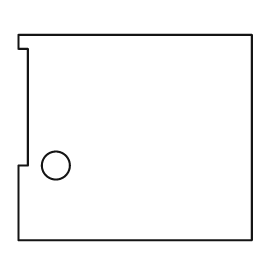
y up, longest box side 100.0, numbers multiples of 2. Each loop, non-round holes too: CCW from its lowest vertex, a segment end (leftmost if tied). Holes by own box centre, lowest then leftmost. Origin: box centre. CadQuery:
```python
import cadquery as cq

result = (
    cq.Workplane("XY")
    .moveTo(-50.0, -44.0)
    .lineTo(50.0, -44.0)
    .lineTo(50.0, 44.0)
    .lineTo(-50.0, 44.0)
    .lineTo(-50.0, 38.0)
    .lineTo(-46.0, 38.0)
    .lineTo(-46.0, -12.0)
    .lineTo(-50.0, -12.0)
    .close()
    .moveTo(-34.0, -12.0)
    .circle(6.0)
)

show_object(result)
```